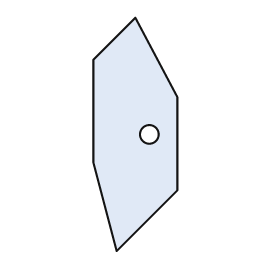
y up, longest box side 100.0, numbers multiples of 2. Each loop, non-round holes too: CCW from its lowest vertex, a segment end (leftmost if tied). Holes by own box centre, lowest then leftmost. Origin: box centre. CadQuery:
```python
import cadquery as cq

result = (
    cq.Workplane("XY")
    .moveTo(-8.0, -50.0)
    .lineTo(18.0, -24.0)
    .lineTo(18.0, 16.0)
    .lineTo(0.0, 50.0)
    .lineTo(-18.0, 32.0)
    .lineTo(-18.0, -12.0)
    .close()
    .moveTo(6.0, 0.0)
    .circle(4.0)
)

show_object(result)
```